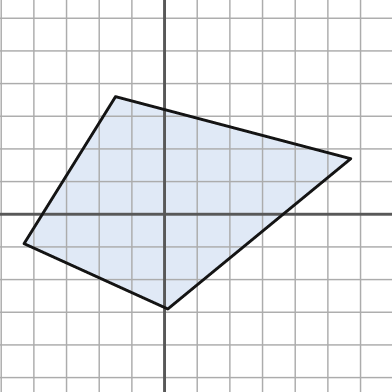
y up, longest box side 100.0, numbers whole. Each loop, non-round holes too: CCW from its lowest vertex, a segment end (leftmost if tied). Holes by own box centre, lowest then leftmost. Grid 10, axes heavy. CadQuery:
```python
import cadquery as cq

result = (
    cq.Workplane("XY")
    .moveTo(1.0, -29.0)
    .lineTo(57.0, 17.0)
    .lineTo(-15.0, 36.0)
    .lineTo(-43.0, -9.0)
    .close()
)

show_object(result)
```